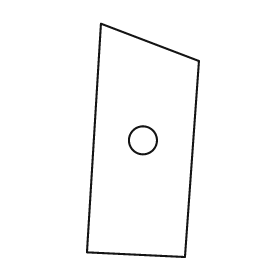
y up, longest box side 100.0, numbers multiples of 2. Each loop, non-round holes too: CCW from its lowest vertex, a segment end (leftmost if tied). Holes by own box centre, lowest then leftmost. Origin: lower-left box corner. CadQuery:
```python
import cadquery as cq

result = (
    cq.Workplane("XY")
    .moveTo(42.0, 0.0)
    .lineTo(48.0, 84.0)
    .lineTo(6.0, 100.0)
    .lineTo(0.0, 2.0)
    .close()
    .moveTo(24.0, 50.0)
    .circle(6.0)
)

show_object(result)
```